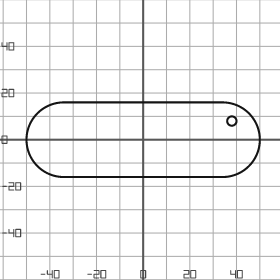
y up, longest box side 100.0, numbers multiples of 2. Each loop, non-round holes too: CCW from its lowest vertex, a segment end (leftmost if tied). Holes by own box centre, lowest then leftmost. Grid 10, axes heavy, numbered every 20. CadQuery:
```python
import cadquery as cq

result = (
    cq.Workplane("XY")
    .moveTo(-34.0, -16.0)
    .lineTo(34.0, -16.0)
    .threePointArc((50.0, 0.0), (34.0, 16.0))
    .lineTo(-34.0, 16.0)
    .threePointArc((-50.0, 0.0), (-34.0, -16.0))
    .close()
    .moveTo(38.0, 8.0)
    .circle(2.0)
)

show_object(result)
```